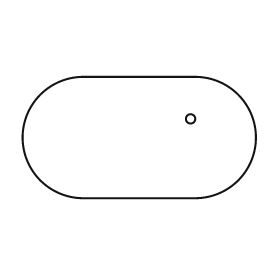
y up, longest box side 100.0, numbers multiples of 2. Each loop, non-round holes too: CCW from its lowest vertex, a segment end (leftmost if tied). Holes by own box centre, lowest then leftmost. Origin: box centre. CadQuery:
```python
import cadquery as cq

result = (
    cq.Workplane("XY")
    .moveTo(-24.0, -26.0)
    .lineTo(24.0, -26.0)
    .threePointArc((50.0, 0.0), (24.0, 26.0))
    .lineTo(-24.0, 26.0)
    .threePointArc((-50.0, 0.0), (-24.0, -26.0))
    .close()
    .moveTo(22.0, 8.0)
    .circle(2.0)
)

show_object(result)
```